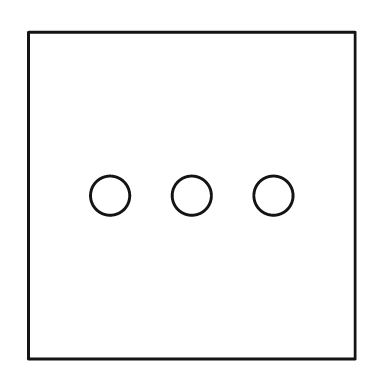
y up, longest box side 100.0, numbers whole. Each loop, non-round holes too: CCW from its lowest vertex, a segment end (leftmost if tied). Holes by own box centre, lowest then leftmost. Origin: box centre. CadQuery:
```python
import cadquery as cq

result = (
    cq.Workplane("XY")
    .moveTo(-50.0, -50.0)
    .lineTo(50.0, -50.0)
    .lineTo(50.0, 50.0)
    .lineTo(-50.0, 50.0)
    .close()
    .moveTo(-25.0, 0.0)
    .circle(6.0)
    .moveTo(0.0, 0.0)
    .circle(6.0)
    .moveTo(25.0, 0.0)
    .circle(6.0)
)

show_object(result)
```